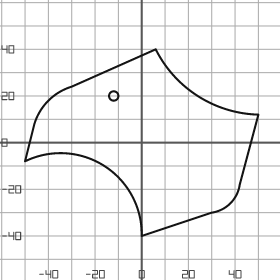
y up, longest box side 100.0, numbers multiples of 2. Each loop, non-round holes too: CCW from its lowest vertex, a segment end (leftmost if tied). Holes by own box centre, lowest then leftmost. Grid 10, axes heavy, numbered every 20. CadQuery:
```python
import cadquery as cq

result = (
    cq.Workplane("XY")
    .moveTo(0.0, -40.0)
    .lineTo(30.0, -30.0)
    .threePointArc((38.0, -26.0), (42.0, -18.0))
    .lineTo(50.0, 12.0)
    .threePointArc((24.0, 20.0), (6.0, 40.0))
    .lineTo(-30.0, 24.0)
    .threePointArc((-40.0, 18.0), (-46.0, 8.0))
    .lineTo(-50.0, -8.0)
    .threePointArc((-16.0, -10.0), (0.0, -40.0))
    .close()
    .moveTo(-12.0, 20.0)
    .circle(2.0)
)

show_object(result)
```